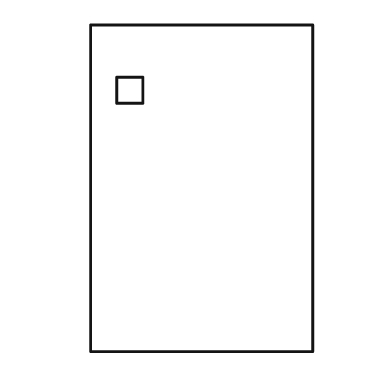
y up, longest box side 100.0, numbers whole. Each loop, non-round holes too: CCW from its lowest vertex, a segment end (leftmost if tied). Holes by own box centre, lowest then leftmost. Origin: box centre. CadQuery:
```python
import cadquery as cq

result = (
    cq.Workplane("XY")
    .moveTo(-34.0, -50.0)
    .lineTo(34.0, -50.0)
    .lineTo(34.0, 50.0)
    .lineTo(-34.0, 50.0)
    .close()
    .moveTo(-26.0, 26.0)
    .lineTo(-18.0, 26.0)
    .lineTo(-18.0, 34.0)
    .lineTo(-26.0, 34.0)
    .close()
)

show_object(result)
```